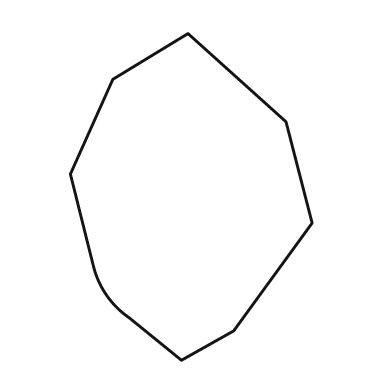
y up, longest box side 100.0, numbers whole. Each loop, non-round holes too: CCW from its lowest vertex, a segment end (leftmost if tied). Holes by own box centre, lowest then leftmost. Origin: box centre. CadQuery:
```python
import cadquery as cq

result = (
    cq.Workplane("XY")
    .moveTo(-3.0, -50.0)
    .lineTo(13.0, -41.0)
    .lineTo(37.0, -8.0)
    .lineTo(29.0, 23.0)
    .lineTo(-1.0, 50.0)
    .lineTo(-24.0, 36.0)
    .lineTo(-37.0, 7.0)
    .lineTo(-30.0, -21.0)
    .threePointArc((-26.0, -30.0), (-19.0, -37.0))
    .close()
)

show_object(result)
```